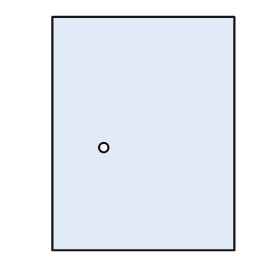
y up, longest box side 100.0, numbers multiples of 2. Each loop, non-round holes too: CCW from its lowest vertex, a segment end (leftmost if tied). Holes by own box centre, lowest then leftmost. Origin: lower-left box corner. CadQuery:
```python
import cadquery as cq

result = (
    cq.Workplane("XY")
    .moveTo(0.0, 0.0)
    .lineTo(78.0, 0.0)
    .lineTo(78.0, 100.0)
    .lineTo(0.0, 100.0)
    .close()
    .moveTo(22.0, 44.0)
    .circle(2.0)
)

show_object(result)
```